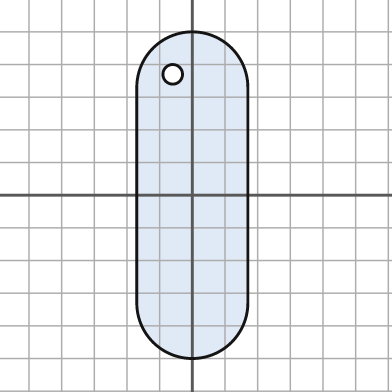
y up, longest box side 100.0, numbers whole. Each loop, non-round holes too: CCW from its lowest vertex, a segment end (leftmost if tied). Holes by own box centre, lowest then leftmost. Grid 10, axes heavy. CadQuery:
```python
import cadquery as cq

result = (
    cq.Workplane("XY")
    .moveTo(-17.0, -33.0)
    .threePointArc((0.0, -50.0), (17.0, -33.0))
    .lineTo(17.0, 33.0)
    .threePointArc((0.0, 50.0), (-17.0, 33.0))
    .close()
    .moveTo(-6.0, 37.0)
    .circle(3.0)
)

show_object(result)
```